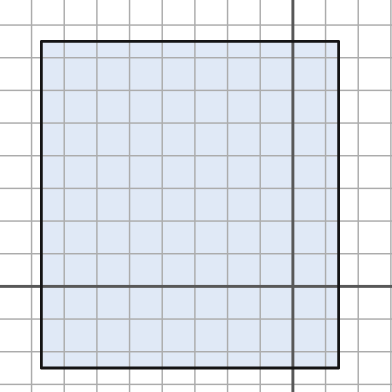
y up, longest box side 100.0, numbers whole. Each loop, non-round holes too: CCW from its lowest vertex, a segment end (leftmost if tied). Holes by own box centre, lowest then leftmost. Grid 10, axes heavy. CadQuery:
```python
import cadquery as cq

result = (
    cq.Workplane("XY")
    .moveTo(-77.0, -25.0)
    .lineTo(14.0, -25.0)
    .lineTo(14.0, 75.0)
    .lineTo(-77.0, 75.0)
    .close()
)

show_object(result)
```